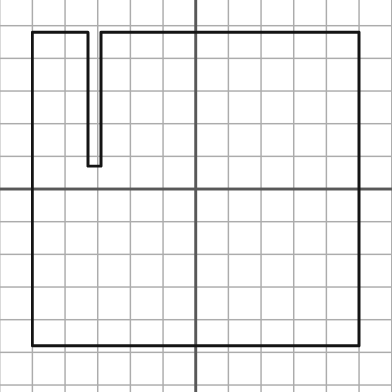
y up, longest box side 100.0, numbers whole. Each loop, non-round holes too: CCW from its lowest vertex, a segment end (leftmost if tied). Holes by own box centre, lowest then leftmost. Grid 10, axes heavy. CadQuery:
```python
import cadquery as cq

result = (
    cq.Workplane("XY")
    .moveTo(-50.0, -48.0)
    .lineTo(50.0, -48.0)
    .lineTo(50.0, 48.0)
    .lineTo(-29.0, 48.0)
    .lineTo(-29.0, 7.0)
    .lineTo(-33.0, 7.0)
    .lineTo(-33.0, 48.0)
    .lineTo(-50.0, 48.0)
    .close()
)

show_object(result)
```